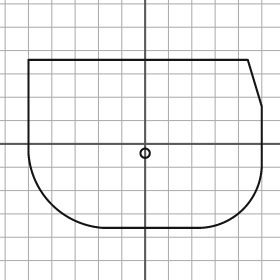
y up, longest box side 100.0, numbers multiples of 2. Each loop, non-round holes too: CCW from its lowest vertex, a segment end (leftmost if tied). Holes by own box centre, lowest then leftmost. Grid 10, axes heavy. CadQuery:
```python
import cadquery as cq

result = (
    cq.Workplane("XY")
    .moveTo(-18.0, -36.0)
    .lineTo(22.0, -36.0)
    .threePointArc((42.0, -28.0), (50.0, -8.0))
    .lineTo(50.0, 16.0)
    .lineTo(44.0, 36.0)
    .lineTo(-50.0, 36.0)
    .lineTo(-50.0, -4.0)
    .threePointArc((-40.0, -26.0), (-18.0, -36.0))
    .close()
    .moveTo(0.0, -4.0)
    .circle(2.0)
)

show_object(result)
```